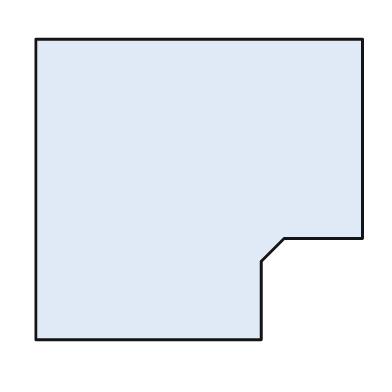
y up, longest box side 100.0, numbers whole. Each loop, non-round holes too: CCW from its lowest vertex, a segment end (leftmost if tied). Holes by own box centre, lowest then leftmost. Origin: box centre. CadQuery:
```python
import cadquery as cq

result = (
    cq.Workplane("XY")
    .moveTo(-50.0, -46.0)
    .lineTo(19.0, -46.0)
    .lineTo(19.0, -22.0)
    .lineTo(26.0, -15.0)
    .lineTo(50.0, -15.0)
    .lineTo(50.0, 46.0)
    .lineTo(-50.0, 46.0)
    .close()
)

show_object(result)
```